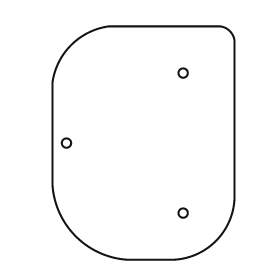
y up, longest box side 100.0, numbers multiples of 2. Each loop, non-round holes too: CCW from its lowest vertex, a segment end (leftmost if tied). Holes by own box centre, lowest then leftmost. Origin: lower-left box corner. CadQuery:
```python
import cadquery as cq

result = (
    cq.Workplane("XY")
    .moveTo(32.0, 0.0)
    .lineTo(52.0, 0.0)
    .threePointArc((70.0, 8.0), (78.0, 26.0))
    .lineTo(78.0, 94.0)
    .threePointArc((76.0, 98.0), (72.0, 100.0))
    .lineTo(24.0, 100.0)
    .threePointArc((8.0, 92.0), (0.0, 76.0))
    .lineTo(0.0, 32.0)
    .threePointArc((10.0, 10.0), (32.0, 0.0))
    .close()
    .moveTo(56.0, 20.0)
    .circle(2.0)
    .moveTo(6.0, 50.0)
    .circle(2.0)
    .moveTo(56.0, 80.0)
    .circle(2.0)
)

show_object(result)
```